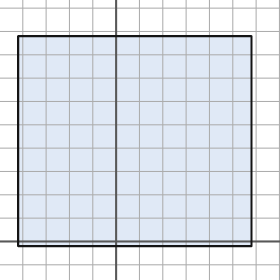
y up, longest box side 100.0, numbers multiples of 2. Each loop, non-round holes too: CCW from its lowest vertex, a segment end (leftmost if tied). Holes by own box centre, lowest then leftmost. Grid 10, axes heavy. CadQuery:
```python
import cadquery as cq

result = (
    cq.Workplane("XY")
    .moveTo(-42.0, -2.0)
    .lineTo(58.0, -2.0)
    .lineTo(58.0, 88.0)
    .lineTo(-42.0, 88.0)
    .close()
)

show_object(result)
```